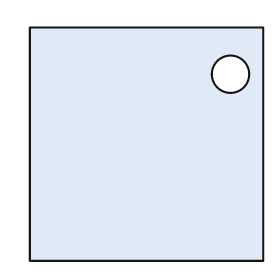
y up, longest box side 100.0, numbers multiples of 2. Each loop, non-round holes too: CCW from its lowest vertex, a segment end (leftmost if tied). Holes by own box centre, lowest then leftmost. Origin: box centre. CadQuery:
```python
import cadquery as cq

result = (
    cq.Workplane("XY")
    .moveTo(-50.0, -50.0)
    .lineTo(50.0, -50.0)
    .lineTo(50.0, 50.0)
    .lineTo(-50.0, 50.0)
    .close()
    .moveTo(36.0, 30.0)
    .circle(8.0)
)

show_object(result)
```